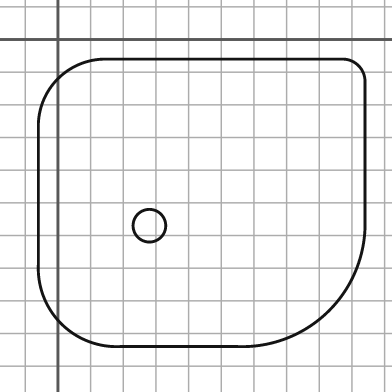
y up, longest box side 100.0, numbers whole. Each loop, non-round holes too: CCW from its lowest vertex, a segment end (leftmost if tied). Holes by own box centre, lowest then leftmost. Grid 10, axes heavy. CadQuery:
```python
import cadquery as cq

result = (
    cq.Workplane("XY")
    .moveTo(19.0, -94.0)
    .lineTo(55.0, -94.0)
    .threePointArc((83.0, -83.0), (94.0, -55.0))
    .lineTo(94.0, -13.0)
    .threePointArc((92.0, -8.0), (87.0, -6.0))
    .lineTo(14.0, -6.0)
    .threePointArc((0.0, -12.0), (-6.0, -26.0))
    .lineTo(-6.0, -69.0)
    .threePointArc((1.0, -87.0), (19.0, -94.0))
    .close()
    .moveTo(28.0, -57.0)
    .circle(5.0)
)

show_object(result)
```